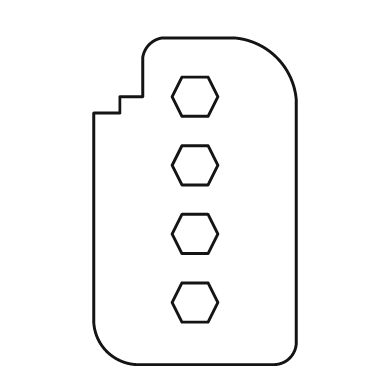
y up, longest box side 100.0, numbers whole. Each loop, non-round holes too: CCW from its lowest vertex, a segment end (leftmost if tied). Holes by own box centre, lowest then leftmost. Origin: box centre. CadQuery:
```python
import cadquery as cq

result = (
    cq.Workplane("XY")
    .moveTo(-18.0, -50.0)
    .lineTo(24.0, -50.0)
    .threePointArc((29.0, -48.0), (31.0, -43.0))
    .lineTo(31.0, 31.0)
    .threePointArc((25.0, 44.0), (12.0, 50.0))
    .lineTo(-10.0, 50.0)
    .threePointArc((-14.0, 48.0), (-16.0, 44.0))
    .lineTo(-16.0, 32.0)
    .lineTo(-23.0, 32.0)
    .lineTo(-23.0, 27.0)
    .lineTo(-31.0, 27.0)
    .lineTo(-31.0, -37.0)
    .threePointArc((-27.0, -46.0), (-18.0, -50.0))
    .close()
    .moveTo(-4.0, -37.0)
    .lineTo(4.0, -37.0)
    .lineTo(7.0, -31.0)
    .lineTo(4.0, -25.0)
    .lineTo(-4.0, -25.0)
    .lineTo(-7.0, -31.0)
    .close()
    .moveTo(-4.0, -16.0)
    .lineTo(4.0, -16.0)
    .lineTo(7.0, -10.0)
    .lineTo(4.0, -4.0)
    .lineTo(-4.0, -4.0)
    .lineTo(-7.0, -10.0)
    .close()
    .moveTo(-4.0, 5.0)
    .lineTo(4.0, 5.0)
    .lineTo(7.0, 11.0)
    .lineTo(4.0, 17.0)
    .lineTo(-4.0, 17.0)
    .lineTo(-7.0, 11.0)
    .close()
    .moveTo(-4.0, 26.0)
    .lineTo(4.0, 26.0)
    .lineTo(7.0, 32.0)
    .lineTo(4.0, 38.0)
    .lineTo(-4.0, 38.0)
    .lineTo(-7.0, 32.0)
    .close()
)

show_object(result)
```